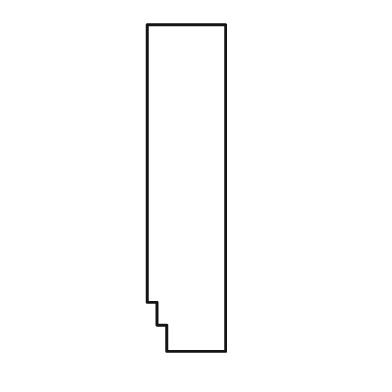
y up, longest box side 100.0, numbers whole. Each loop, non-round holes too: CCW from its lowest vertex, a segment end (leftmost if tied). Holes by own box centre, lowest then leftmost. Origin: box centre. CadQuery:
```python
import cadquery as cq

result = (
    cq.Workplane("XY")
    .moveTo(-6.0, -50.0)
    .lineTo(12.0, -50.0)
    .lineTo(12.0, 50.0)
    .lineTo(-12.0, 50.0)
    .lineTo(-12.0, -35.0)
    .lineTo(-9.0, -35.0)
    .lineTo(-9.0, -42.0)
    .lineTo(-6.0, -42.0)
    .close()
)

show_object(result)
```